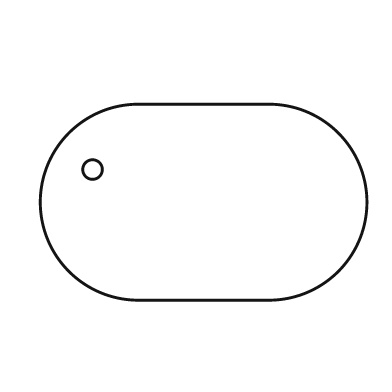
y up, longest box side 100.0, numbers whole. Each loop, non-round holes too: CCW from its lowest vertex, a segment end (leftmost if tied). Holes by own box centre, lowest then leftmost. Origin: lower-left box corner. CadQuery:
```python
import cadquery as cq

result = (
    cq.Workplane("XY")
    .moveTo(30.0, 0.0)
    .lineTo(70.0, 0.0)
    .threePointArc((100.0, 30.0), (70.0, 60.0))
    .lineTo(30.0, 60.0)
    .threePointArc((0.0, 30.0), (30.0, 0.0))
    .close()
    .moveTo(16.0, 40.0)
    .circle(3.0)
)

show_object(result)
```